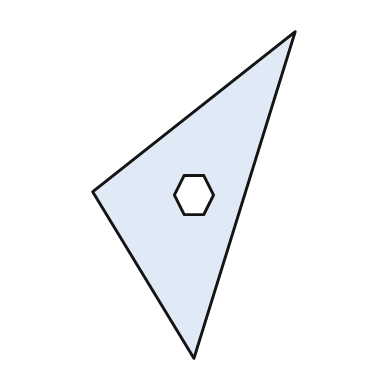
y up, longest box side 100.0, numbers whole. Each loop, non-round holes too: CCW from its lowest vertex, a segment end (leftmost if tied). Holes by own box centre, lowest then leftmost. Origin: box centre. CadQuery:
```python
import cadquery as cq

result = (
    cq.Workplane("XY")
    .moveTo(0.0, -50.0)
    .lineTo(31.0, 50.0)
    .lineTo(-31.0, 1.0)
    .close()
    .moveTo(-3.0, -6.0)
    .lineTo(3.0, -6.0)
    .lineTo(6.0, 0.0)
    .lineTo(3.0, 6.0)
    .lineTo(-3.0, 6.0)
    .lineTo(-6.0, 0.0)
    .close()
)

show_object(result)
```